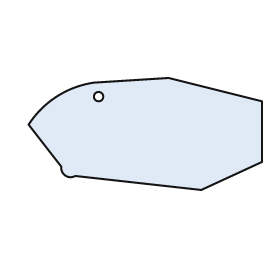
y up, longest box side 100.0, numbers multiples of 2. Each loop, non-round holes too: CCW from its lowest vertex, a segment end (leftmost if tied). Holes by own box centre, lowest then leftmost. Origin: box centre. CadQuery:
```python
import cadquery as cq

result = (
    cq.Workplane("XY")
    .moveTo(24.0, -24.0)
    .lineTo(50.0, -12.0)
    .lineTo(50.0, 14.0)
    .lineTo(10.0, 24.0)
    .lineTo(-22.0, 22.0)
    .threePointArc((-38.0, 16.0), (-50.0, 4.0))
    .lineTo(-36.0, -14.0)
    .threePointArc((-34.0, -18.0), (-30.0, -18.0))
    .close()
    .moveTo(-20.0, 16.0)
    .circle(2.0)
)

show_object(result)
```